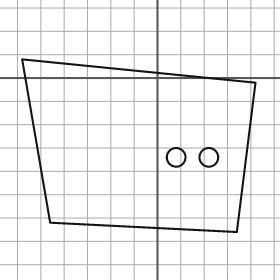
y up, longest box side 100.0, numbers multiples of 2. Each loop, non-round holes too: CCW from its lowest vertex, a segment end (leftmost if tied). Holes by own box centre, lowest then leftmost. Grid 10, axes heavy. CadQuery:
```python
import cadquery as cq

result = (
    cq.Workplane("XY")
    .moveTo(34.0, -66.0)
    .lineTo(42.0, -2.0)
    .lineTo(-58.0, 8.0)
    .lineTo(-46.0, -62.0)
    .close()
    .moveTo(8.0, -34.0)
    .circle(4.0)
    .moveTo(22.0, -34.0)
    .circle(4.0)
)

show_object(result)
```